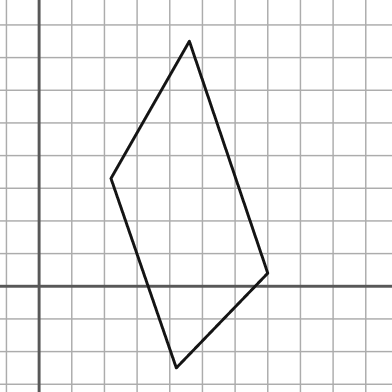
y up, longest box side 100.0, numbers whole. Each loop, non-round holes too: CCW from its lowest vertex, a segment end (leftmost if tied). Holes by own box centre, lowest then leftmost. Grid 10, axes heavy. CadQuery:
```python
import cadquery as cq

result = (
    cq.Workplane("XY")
    .moveTo(42.0, -25.0)
    .lineTo(70.0, 4.0)
    .lineTo(46.0, 75.0)
    .lineTo(22.0, 33.0)
    .close()
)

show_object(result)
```